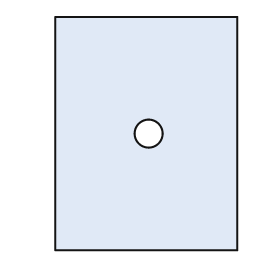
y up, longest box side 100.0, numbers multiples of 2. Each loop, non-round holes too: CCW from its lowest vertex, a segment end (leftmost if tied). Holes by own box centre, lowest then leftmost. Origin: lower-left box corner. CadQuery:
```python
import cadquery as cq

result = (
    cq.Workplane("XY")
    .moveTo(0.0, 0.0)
    .lineTo(78.0, 0.0)
    .lineTo(78.0, 100.0)
    .lineTo(0.0, 100.0)
    .close()
    .moveTo(40.0, 50.0)
    .circle(6.0)
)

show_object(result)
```